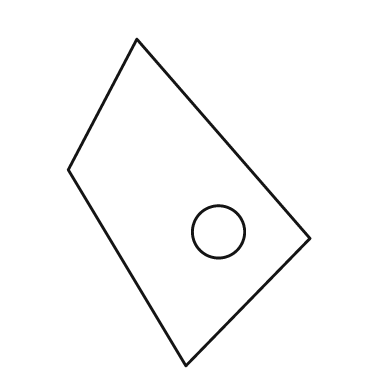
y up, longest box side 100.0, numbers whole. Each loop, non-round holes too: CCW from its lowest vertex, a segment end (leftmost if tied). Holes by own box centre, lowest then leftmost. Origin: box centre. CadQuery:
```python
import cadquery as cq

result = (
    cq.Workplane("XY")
    .moveTo(-1.0, -50.0)
    .lineTo(37.0, -11.0)
    .lineTo(-16.0, 50.0)
    .lineTo(-37.0, 10.0)
    .close()
    .moveTo(9.0, -9.0)
    .circle(8.0)
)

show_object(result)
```